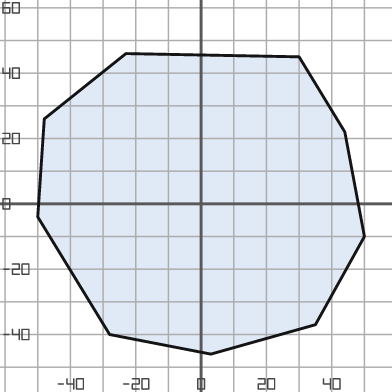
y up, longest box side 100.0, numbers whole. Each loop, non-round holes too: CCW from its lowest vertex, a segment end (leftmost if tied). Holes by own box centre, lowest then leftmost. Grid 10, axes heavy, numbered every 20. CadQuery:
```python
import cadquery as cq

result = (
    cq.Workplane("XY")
    .moveTo(3.0, -46.0)
    .lineTo(35.0, -37.0)
    .lineTo(50.0, -10.0)
    .lineTo(44.0, 22.0)
    .lineTo(30.0, 45.0)
    .lineTo(-23.0, 46.0)
    .lineTo(-48.0, 26.0)
    .lineTo(-50.0, -4.0)
    .lineTo(-28.0, -40.0)
    .close()
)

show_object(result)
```